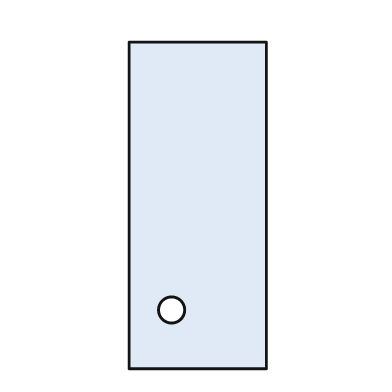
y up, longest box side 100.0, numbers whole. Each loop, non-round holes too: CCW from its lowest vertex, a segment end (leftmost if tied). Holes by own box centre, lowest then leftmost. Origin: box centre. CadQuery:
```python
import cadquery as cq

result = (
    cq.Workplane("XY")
    .moveTo(-21.0, -50.0)
    .lineTo(21.0, -50.0)
    .lineTo(21.0, 50.0)
    .lineTo(-21.0, 50.0)
    .close()
    .moveTo(-8.0, -32.0)
    .circle(4.0)
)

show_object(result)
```